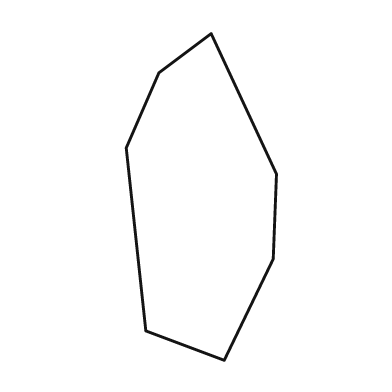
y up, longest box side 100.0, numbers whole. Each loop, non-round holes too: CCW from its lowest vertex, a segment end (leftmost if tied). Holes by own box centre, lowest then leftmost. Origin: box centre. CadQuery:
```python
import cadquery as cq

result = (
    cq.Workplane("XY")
    .moveTo(7.0, -50.0)
    .lineTo(22.0, -19.0)
    .lineTo(23.0, 7.0)
    .lineTo(3.0, 50.0)
    .lineTo(-13.0, 38.0)
    .lineTo(-23.0, 15.0)
    .lineTo(-17.0, -41.0)
    .close()
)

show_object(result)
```